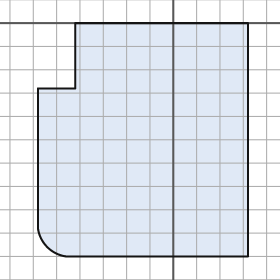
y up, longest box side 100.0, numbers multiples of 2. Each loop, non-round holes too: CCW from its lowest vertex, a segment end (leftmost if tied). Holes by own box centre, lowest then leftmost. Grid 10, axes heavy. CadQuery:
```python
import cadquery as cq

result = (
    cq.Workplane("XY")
    .moveTo(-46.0, -100.0)
    .lineTo(32.0, -100.0)
    .lineTo(32.0, 0.0)
    .lineTo(-42.0, 0.0)
    .lineTo(-42.0, -28.0)
    .lineTo(-58.0, -28.0)
    .lineTo(-58.0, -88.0)
    .threePointArc((-54.0, -96.0), (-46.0, -100.0))
    .close()
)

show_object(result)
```